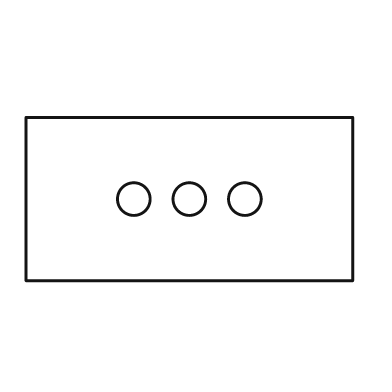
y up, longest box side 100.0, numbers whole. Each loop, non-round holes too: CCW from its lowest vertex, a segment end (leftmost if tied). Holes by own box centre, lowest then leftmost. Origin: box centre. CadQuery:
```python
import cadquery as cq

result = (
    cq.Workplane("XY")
    .moveTo(-50.0, -25.0)
    .lineTo(50.0, -25.0)
    .lineTo(50.0, 25.0)
    .lineTo(-50.0, 25.0)
    .close()
    .moveTo(-17.0, 0.0)
    .circle(5.0)
    .moveTo(0.0, 0.0)
    .circle(5.0)
    .moveTo(17.0, 0.0)
    .circle(5.0)
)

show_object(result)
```